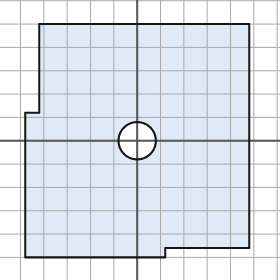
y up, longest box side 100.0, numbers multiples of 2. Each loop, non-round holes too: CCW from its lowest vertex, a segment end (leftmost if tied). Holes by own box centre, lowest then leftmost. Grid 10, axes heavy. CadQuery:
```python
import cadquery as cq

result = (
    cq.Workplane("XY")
    .moveTo(-48.0, -50.0)
    .lineTo(12.0, -50.0)
    .lineTo(12.0, -46.0)
    .lineTo(48.0, -46.0)
    .lineTo(48.0, 50.0)
    .lineTo(-42.0, 50.0)
    .lineTo(-42.0, 12.0)
    .lineTo(-48.0, 12.0)
    .close()
    .moveTo(0.0, 0.0)
    .circle(8.0)
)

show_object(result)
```